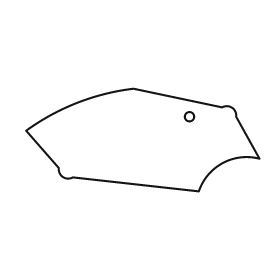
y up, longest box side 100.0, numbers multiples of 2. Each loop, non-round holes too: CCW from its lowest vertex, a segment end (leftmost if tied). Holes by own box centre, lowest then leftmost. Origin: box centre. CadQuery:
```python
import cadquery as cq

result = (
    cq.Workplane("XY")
    .moveTo(24.0, -22.0)
    .threePointArc((34.0, -10.0), (50.0, -8.0))
    .lineTo(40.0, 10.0)
    .threePointArc((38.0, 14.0), (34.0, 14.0))
    .lineTo(-4.0, 22.0)
    .threePointArc((-28.0, 16.0), (-50.0, 4.0))
    .lineTo(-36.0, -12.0)
    .threePointArc((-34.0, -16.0), (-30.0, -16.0))
    .close()
    .moveTo(20.0, 10.0)
    .circle(2.0)
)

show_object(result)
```